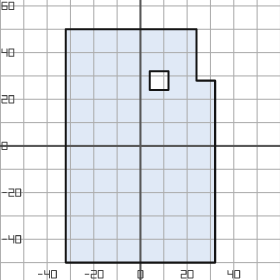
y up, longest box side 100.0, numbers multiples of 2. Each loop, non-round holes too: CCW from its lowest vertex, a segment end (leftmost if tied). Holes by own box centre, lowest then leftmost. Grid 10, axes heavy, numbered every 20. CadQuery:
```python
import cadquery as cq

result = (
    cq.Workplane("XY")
    .moveTo(-32.0, -50.0)
    .lineTo(32.0, -50.0)
    .lineTo(32.0, 28.0)
    .lineTo(24.0, 28.0)
    .lineTo(24.0, 50.0)
    .lineTo(-32.0, 50.0)
    .close()
    .moveTo(4.0, 24.0)
    .lineTo(12.0, 24.0)
    .lineTo(12.0, 32.0)
    .lineTo(4.0, 32.0)
    .close()
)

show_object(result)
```